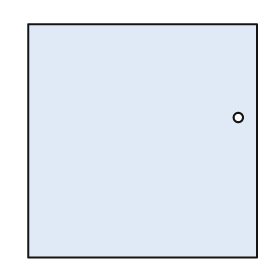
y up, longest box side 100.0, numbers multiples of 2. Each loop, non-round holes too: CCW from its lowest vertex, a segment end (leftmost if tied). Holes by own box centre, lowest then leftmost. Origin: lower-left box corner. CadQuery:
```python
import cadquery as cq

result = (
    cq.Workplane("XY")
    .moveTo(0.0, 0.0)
    .lineTo(98.0, 0.0)
    .lineTo(98.0, 100.0)
    .lineTo(0.0, 100.0)
    .close()
    .moveTo(90.0, 60.0)
    .circle(2.0)
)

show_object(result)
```